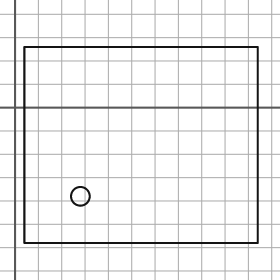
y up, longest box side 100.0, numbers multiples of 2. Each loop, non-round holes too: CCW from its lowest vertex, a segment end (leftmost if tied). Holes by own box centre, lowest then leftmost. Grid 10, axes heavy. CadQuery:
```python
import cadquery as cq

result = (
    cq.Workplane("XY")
    .moveTo(4.0, -58.0)
    .lineTo(104.0, -58.0)
    .lineTo(104.0, 26.0)
    .lineTo(4.0, 26.0)
    .close()
    .moveTo(28.0, -38.0)
    .circle(4.0)
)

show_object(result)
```